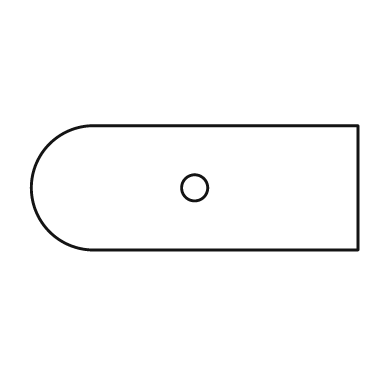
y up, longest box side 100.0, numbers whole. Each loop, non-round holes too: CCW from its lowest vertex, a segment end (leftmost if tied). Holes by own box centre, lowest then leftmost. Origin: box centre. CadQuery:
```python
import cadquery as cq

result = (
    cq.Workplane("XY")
    .moveTo(-32.0, -19.0)
    .lineTo(50.0, -19.0)
    .lineTo(50.0, 19.0)
    .lineTo(-32.0, 19.0)
    .threePointArc((-50.0, 0.0), (-32.0, -19.0))
    .close()
    .moveTo(0.0, 0.0)
    .circle(4.0)
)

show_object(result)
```